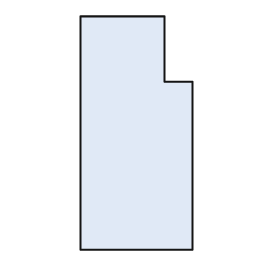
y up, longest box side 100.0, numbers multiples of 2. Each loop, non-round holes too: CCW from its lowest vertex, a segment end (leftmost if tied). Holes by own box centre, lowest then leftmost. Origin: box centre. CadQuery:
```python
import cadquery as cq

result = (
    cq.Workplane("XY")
    .moveTo(-24.0, -50.0)
    .lineTo(24.0, -50.0)
    .lineTo(24.0, 22.0)
    .lineTo(12.0, 22.0)
    .lineTo(12.0, 50.0)
    .lineTo(-24.0, 50.0)
    .close()
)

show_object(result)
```